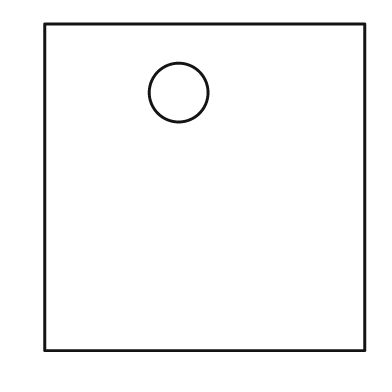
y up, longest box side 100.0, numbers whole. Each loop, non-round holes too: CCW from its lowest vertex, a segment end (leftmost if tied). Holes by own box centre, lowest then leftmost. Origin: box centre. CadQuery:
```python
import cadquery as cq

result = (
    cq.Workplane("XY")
    .moveTo(-49.0, -50.0)
    .lineTo(49.0, -50.0)
    .lineTo(49.0, 50.0)
    .lineTo(-49.0, 50.0)
    .close()
    .moveTo(-8.0, 29.0)
    .circle(9.0)
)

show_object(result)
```